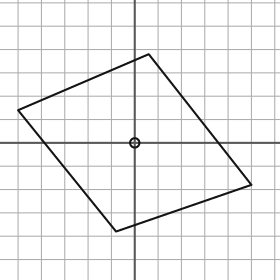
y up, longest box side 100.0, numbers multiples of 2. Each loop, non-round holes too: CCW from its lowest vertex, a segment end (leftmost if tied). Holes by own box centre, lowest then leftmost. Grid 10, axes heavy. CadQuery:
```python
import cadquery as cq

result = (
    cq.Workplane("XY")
    .moveTo(-8.0, -38.0)
    .lineTo(50.0, -18.0)
    .lineTo(6.0, 38.0)
    .lineTo(-50.0, 14.0)
    .close()
    .moveTo(0.0, 0.0)
    .circle(2.0)
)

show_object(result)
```